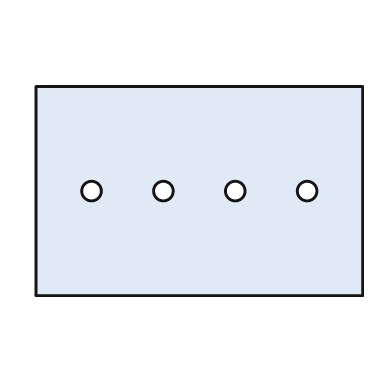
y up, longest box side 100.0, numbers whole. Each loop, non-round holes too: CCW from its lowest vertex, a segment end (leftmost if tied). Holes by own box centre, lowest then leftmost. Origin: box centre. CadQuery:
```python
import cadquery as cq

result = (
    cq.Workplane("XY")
    .moveTo(-50.0, -32.0)
    .lineTo(50.0, -32.0)
    .lineTo(50.0, 32.0)
    .lineTo(-50.0, 32.0)
    .close()
    .moveTo(-33.0, 0.0)
    .circle(3.0)
    .moveTo(-11.0, 0.0)
    .circle(3.0)
    .moveTo(11.0, 0.0)
    .circle(3.0)
    .moveTo(33.0, 0.0)
    .circle(3.0)
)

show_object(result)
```